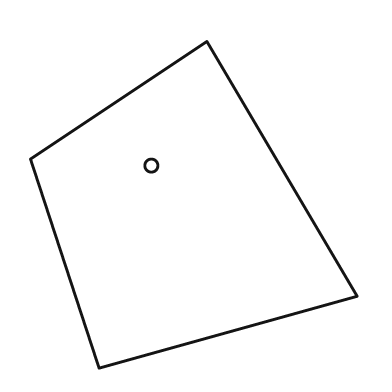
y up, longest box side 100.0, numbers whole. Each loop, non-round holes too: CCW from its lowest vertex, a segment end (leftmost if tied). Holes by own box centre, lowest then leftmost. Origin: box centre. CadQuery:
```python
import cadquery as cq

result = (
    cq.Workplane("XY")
    .moveTo(-29.0, -50.0)
    .lineTo(50.0, -28.0)
    .lineTo(4.0, 50.0)
    .lineTo(-50.0, 14.0)
    .close()
    .moveTo(-13.0, 12.0)
    .circle(2.0)
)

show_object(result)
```